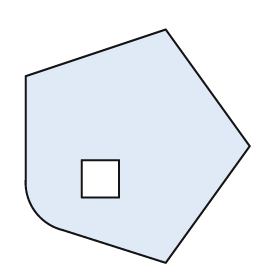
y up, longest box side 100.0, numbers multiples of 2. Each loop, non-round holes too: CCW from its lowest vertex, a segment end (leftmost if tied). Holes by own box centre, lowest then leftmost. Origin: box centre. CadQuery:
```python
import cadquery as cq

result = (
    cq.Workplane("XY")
    .moveTo(12.0, -50.0)
    .lineTo(48.0, 0.0)
    .lineTo(12.0, 50.0)
    .lineTo(-48.0, 30.0)
    .lineTo(-48.0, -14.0)
    .threePointArc((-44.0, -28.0), (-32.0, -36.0))
    .close()
    .moveTo(-24.0, -22.0)
    .lineTo(-8.0, -22.0)
    .lineTo(-8.0, -6.0)
    .lineTo(-24.0, -6.0)
    .close()
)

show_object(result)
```